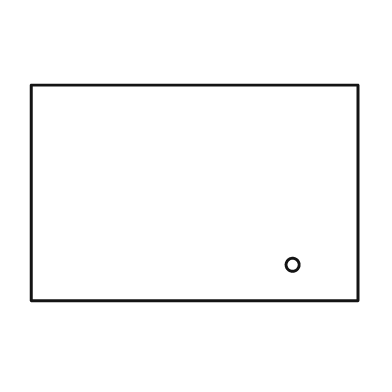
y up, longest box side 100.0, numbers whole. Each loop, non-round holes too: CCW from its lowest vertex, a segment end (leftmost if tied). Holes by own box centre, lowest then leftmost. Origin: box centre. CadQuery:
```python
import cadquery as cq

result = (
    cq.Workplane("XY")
    .moveTo(-50.0, -33.0)
    .lineTo(50.0, -33.0)
    .lineTo(50.0, 33.0)
    .lineTo(-50.0, 33.0)
    .close()
    .moveTo(30.0, -22.0)
    .circle(2.0)
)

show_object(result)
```